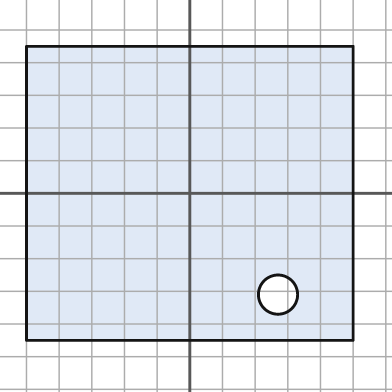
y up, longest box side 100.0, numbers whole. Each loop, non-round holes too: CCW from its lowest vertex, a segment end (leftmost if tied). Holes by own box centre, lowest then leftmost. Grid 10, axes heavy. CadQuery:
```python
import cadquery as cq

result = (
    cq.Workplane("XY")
    .moveTo(-50.0, -45.0)
    .lineTo(50.0, -45.0)
    .lineTo(50.0, 45.0)
    .lineTo(-50.0, 45.0)
    .close()
    .moveTo(27.0, -31.0)
    .circle(6.0)
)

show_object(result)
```